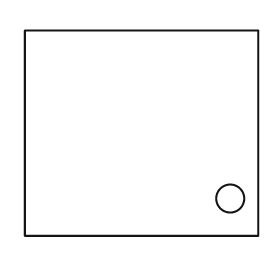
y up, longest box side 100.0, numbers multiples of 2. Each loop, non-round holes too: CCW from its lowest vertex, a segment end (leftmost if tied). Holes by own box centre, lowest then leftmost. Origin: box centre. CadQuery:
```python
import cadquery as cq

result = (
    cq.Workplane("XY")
    .moveTo(-50.0, -44.0)
    .lineTo(50.0, -44.0)
    .lineTo(50.0, 44.0)
    .lineTo(-50.0, 44.0)
    .close()
    .moveTo(38.0, -28.0)
    .circle(6.0)
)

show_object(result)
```